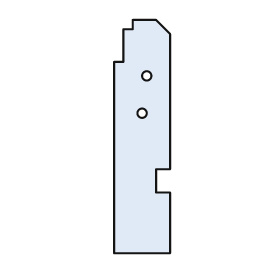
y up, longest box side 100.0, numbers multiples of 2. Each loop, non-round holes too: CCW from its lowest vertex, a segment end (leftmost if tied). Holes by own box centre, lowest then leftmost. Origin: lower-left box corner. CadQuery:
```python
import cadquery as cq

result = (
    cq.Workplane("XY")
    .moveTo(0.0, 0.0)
    .lineTo(24.0, 0.0)
    .lineTo(24.0, 26.0)
    .lineTo(18.0, 26.0)
    .lineTo(18.0, 36.0)
    .lineTo(24.0, 36.0)
    .lineTo(24.0, 94.0)
    .lineTo(18.0, 100.0)
    .lineTo(8.0, 100.0)
    .lineTo(8.0, 96.0)
    .lineTo(4.0, 96.0)
    .lineTo(4.0, 82.0)
    .lineTo(0.0, 82.0)
    .close()
    .moveTo(12.0, 60.0)
    .circle(2.0)
    .moveTo(14.0, 76.0)
    .circle(2.0)
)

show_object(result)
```